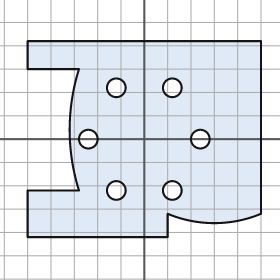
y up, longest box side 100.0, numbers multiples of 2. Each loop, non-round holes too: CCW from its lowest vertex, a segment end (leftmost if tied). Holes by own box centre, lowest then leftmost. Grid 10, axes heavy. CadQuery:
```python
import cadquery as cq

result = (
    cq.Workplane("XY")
    .moveTo(-50.0, -42.0)
    .lineTo(10.0, -42.0)
    .lineTo(10.0, -32.0)
    .threePointArc((30.0, -36.0), (50.0, -32.0))
    .lineTo(50.0, 42.0)
    .lineTo(-50.0, 42.0)
    .lineTo(-50.0, 30.0)
    .lineTo(-28.0, 30.0)
    .threePointArc((-32.0, 4.0), (-28.0, -22.0))
    .lineTo(-50.0, -22.0)
    .close()
    .moveTo(-12.0, -22.0)
    .circle(4.0)
    .moveTo(12.0, -22.0)
    .circle(4.0)
    .moveTo(-24.0, 0.0)
    .circle(4.0)
    .moveTo(24.0, 0.0)
    .circle(4.0)
    .moveTo(-12.0, 22.0)
    .circle(4.0)
    .moveTo(12.0, 22.0)
    .circle(4.0)
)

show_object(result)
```